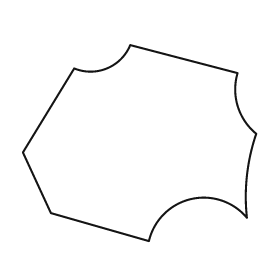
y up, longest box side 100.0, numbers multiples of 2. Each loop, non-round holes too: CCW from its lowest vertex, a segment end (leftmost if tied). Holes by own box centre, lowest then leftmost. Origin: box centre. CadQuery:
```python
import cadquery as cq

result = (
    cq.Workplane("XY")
    .moveTo(4.0, -42.0)
    .threePointArc((22.0, -24.0), (46.0, -32.0))
    .threePointArc((46.0, -14.0), (50.0, 4.0))
    .threePointArc((42.0, 16.0), (42.0, 30.0))
    .lineTo(-4.0, 42.0)
    .threePointArc((-14.0, 32.0), (-28.0, 32.0))
    .lineTo(-50.0, -4.0)
    .lineTo(-38.0, -30.0)
    .close()
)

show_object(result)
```